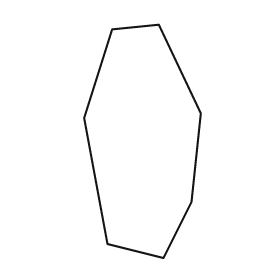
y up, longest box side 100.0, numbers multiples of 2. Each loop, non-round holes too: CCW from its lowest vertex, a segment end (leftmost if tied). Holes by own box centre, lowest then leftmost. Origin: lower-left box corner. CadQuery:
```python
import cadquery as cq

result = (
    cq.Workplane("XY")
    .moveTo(34.0, 0.0)
    .lineTo(46.0, 24.0)
    .lineTo(50.0, 62.0)
    .lineTo(32.0, 100.0)
    .lineTo(12.0, 98.0)
    .lineTo(0.0, 60.0)
    .lineTo(10.0, 6.0)
    .close()
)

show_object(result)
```